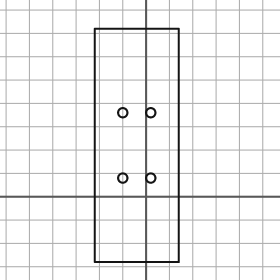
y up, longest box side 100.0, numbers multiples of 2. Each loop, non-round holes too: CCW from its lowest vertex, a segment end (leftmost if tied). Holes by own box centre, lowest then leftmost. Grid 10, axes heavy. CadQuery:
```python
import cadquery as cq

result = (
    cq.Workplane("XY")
    .moveTo(-22.0, -28.0)
    .lineTo(14.0, -28.0)
    .lineTo(14.0, 72.0)
    .lineTo(-22.0, 72.0)
    .close()
    .moveTo(-10.0, 8.0)
    .circle(2.0)
    .moveTo(2.0, 8.0)
    .circle(2.0)
    .moveTo(-10.0, 36.0)
    .circle(2.0)
    .moveTo(2.0, 36.0)
    .circle(2.0)
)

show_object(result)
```